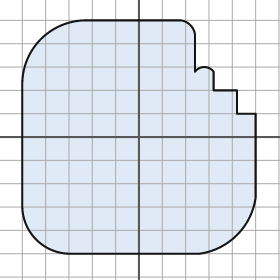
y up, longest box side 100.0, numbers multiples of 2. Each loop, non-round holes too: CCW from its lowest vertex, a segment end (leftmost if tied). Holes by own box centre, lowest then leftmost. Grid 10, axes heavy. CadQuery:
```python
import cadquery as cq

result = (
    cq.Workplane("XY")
    .moveTo(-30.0, -50.0)
    .lineTo(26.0, -50.0)
    .threePointArc((42.0, -42.0), (50.0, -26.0))
    .lineTo(50.0, 10.0)
    .lineTo(42.0, 10.0)
    .lineTo(42.0, 20.0)
    .lineTo(32.0, 20.0)
    .lineTo(32.0, 28.0)
    .threePointArc((28.0, 30.0), (24.0, 28.0))
    .lineTo(24.0, 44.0)
    .threePointArc((22.0, 48.0), (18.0, 50.0))
    .lineTo(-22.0, 50.0)
    .threePointArc((-42.0, 42.0), (-50.0, 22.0))
    .lineTo(-50.0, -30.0)
    .threePointArc((-44.0, -44.0), (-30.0, -50.0))
    .close()
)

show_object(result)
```